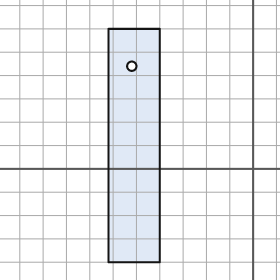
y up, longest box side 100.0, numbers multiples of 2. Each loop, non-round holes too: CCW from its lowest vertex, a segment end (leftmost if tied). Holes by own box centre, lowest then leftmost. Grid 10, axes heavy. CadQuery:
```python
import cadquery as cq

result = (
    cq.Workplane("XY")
    .moveTo(-62.0, -40.0)
    .lineTo(-40.0, -40.0)
    .lineTo(-40.0, 60.0)
    .lineTo(-62.0, 60.0)
    .close()
    .moveTo(-52.0, 44.0)
    .circle(2.0)
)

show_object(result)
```